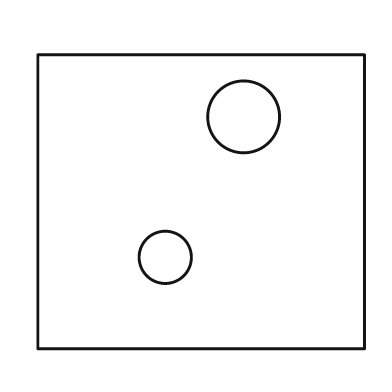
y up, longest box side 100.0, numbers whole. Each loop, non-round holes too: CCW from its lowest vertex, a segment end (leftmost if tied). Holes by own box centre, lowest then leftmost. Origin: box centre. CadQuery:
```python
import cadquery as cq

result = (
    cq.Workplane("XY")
    .moveTo(-50.0, -45.0)
    .lineTo(50.0, -45.0)
    .lineTo(50.0, 45.0)
    .lineTo(-50.0, 45.0)
    .close()
    .moveTo(-11.0, -17.0)
    .circle(8.0)
    .moveTo(13.0, 26.0)
    .circle(11.0)
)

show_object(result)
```